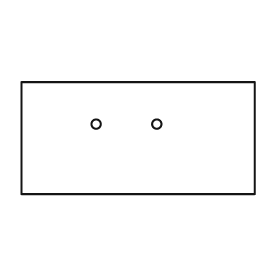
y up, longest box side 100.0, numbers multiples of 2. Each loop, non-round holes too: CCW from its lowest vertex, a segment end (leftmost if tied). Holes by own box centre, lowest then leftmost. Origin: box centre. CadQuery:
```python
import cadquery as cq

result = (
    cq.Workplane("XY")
    .moveTo(-50.0, -24.0)
    .lineTo(50.0, -24.0)
    .lineTo(50.0, 24.0)
    .lineTo(-50.0, 24.0)
    .close()
    .moveTo(-18.0, 6.0)
    .circle(2.0)
    .moveTo(8.0, 6.0)
    .circle(2.0)
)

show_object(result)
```